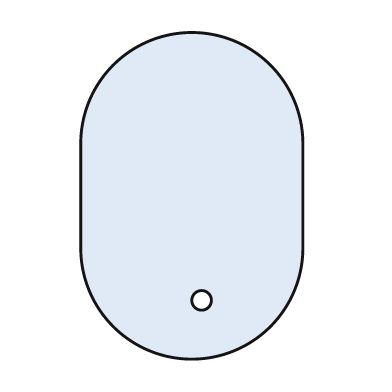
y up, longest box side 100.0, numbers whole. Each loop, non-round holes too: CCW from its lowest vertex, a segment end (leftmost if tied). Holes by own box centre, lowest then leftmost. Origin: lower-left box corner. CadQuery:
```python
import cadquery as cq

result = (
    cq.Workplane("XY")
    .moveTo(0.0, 34.0)
    .threePointArc((34.0, 0.0), (68.0, 34.0))
    .lineTo(68.0, 66.0)
    .threePointArc((34.0, 100.0), (0.0, 66.0))
    .close()
    .moveTo(37.0, 18.0)
    .circle(3.0)
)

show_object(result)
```